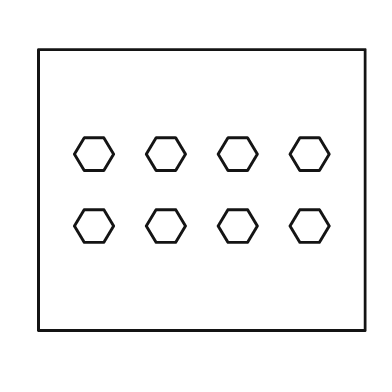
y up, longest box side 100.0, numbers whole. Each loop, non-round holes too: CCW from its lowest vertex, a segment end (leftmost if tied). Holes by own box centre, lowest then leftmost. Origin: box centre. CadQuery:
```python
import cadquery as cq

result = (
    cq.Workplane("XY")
    .moveTo(-50.0, -43.0)
    .lineTo(50.0, -43.0)
    .lineTo(50.0, 43.0)
    .lineTo(-50.0, 43.0)
    .close()
    .moveTo(-36.0, -16.0)
    .lineTo(-30.0, -16.0)
    .lineTo(-27.0, -11.0)
    .lineTo(-30.0, -6.0)
    .lineTo(-36.0, -6.0)
    .lineTo(-39.0, -11.0)
    .close()
    .moveTo(-14.0, -16.0)
    .lineTo(-8.0, -16.0)
    .lineTo(-5.0, -11.0)
    .lineTo(-8.0, -6.0)
    .lineTo(-14.0, -6.0)
    .lineTo(-17.0, -11.0)
    .close()
    .moveTo(8.0, -16.0)
    .lineTo(14.0, -16.0)
    .lineTo(17.0, -11.0)
    .lineTo(14.0, -6.0)
    .lineTo(8.0, -6.0)
    .lineTo(5.0, -11.0)
    .close()
    .moveTo(30.0, -16.0)
    .lineTo(36.0, -16.0)
    .lineTo(39.0, -11.0)
    .lineTo(36.0, -6.0)
    .lineTo(30.0, -6.0)
    .lineTo(27.0, -11.0)
    .close()
    .moveTo(-36.0, 6.0)
    .lineTo(-30.0, 6.0)
    .lineTo(-27.0, 11.0)
    .lineTo(-30.0, 16.0)
    .lineTo(-36.0, 16.0)
    .lineTo(-39.0, 11.0)
    .close()
    .moveTo(-14.0, 6.0)
    .lineTo(-8.0, 6.0)
    .lineTo(-5.0, 11.0)
    .lineTo(-8.0, 16.0)
    .lineTo(-14.0, 16.0)
    .lineTo(-17.0, 11.0)
    .close()
    .moveTo(8.0, 6.0)
    .lineTo(14.0, 6.0)
    .lineTo(17.0, 11.0)
    .lineTo(14.0, 16.0)
    .lineTo(8.0, 16.0)
    .lineTo(5.0, 11.0)
    .close()
    .moveTo(30.0, 6.0)
    .lineTo(36.0, 6.0)
    .lineTo(39.0, 11.0)
    .lineTo(36.0, 16.0)
    .lineTo(30.0, 16.0)
    .lineTo(27.0, 11.0)
    .close()
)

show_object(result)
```